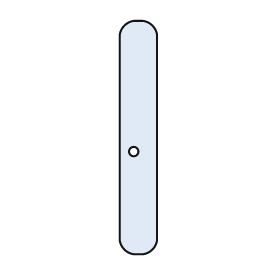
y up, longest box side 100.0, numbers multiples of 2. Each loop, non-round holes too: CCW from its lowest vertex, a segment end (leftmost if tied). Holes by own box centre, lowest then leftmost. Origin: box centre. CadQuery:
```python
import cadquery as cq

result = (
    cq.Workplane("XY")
    .moveTo(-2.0, -50.0)
    .lineTo(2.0, -50.0)
    .threePointArc((6.0, -48.0), (8.0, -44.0))
    .lineTo(8.0, 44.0)
    .threePointArc((6.0, 48.0), (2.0, 50.0))
    .lineTo(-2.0, 50.0)
    .threePointArc((-6.0, 48.0), (-8.0, 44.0))
    .lineTo(-8.0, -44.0)
    .threePointArc((-6.0, -48.0), (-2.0, -50.0))
    .close()
    .moveTo(-2.0, -6.0)
    .circle(2.0)
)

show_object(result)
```